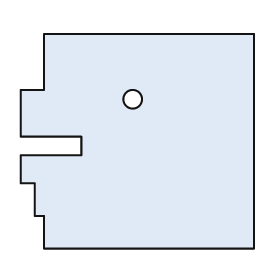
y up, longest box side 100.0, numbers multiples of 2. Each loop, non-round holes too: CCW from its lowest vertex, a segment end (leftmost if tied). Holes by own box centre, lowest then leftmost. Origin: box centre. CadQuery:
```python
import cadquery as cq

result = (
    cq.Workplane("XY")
    .moveTo(-40.0, -46.0)
    .lineTo(50.0, -46.0)
    .lineTo(50.0, 46.0)
    .lineTo(-40.0, 46.0)
    .lineTo(-40.0, 22.0)
    .lineTo(-50.0, 22.0)
    .lineTo(-50.0, 2.0)
    .lineTo(-24.0, 2.0)
    .lineTo(-24.0, -6.0)
    .lineTo(-50.0, -6.0)
    .lineTo(-50.0, -18.0)
    .lineTo(-44.0, -18.0)
    .lineTo(-44.0, -32.0)
    .lineTo(-40.0, -32.0)
    .close()
    .moveTo(-2.0, 18.0)
    .circle(4.0)
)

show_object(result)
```